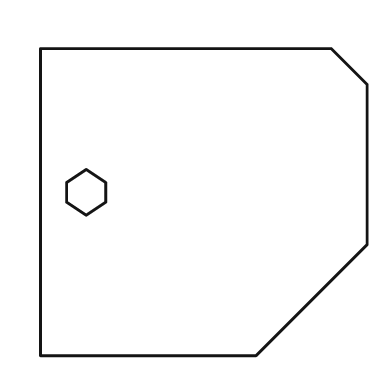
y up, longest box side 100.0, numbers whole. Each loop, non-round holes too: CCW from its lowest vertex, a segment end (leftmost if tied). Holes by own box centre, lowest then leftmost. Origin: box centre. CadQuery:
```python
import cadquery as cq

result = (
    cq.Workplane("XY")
    .moveTo(-50.0, -47.0)
    .lineTo(16.0, -47.0)
    .lineTo(50.0, -13.0)
    .lineTo(50.0, 36.0)
    .lineTo(39.0, 47.0)
    .lineTo(-50.0, 47.0)
    .close()
    .moveTo(-36.0, -4.0)
    .lineTo(-30.0, 0.0)
    .lineTo(-30.0, 6.0)
    .lineTo(-36.0, 10.0)
    .lineTo(-42.0, 6.0)
    .lineTo(-42.0, 0.0)
    .close()
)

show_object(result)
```